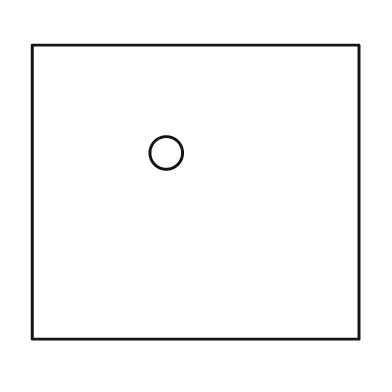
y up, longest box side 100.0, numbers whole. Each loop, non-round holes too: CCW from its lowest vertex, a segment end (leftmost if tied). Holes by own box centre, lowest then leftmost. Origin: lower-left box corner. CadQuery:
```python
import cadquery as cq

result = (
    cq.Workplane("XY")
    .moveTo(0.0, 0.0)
    .lineTo(100.0, 0.0)
    .lineTo(100.0, 90.0)
    .lineTo(0.0, 90.0)
    .close()
    .moveTo(41.0, 57.0)
    .circle(5.0)
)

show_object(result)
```